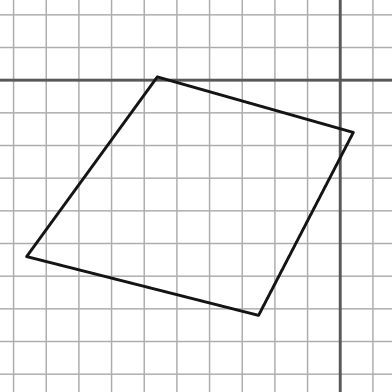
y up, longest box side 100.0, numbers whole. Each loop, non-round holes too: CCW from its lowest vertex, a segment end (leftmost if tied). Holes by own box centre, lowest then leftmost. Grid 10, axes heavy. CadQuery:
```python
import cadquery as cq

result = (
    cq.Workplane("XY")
    .moveTo(-25.0, -72.0)
    .lineTo(4.0, -16.0)
    .lineTo(-56.0, 1.0)
    .lineTo(-96.0, -54.0)
    .close()
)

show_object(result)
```